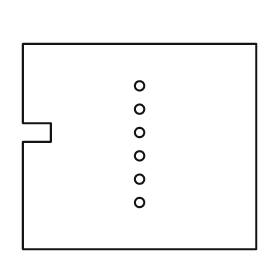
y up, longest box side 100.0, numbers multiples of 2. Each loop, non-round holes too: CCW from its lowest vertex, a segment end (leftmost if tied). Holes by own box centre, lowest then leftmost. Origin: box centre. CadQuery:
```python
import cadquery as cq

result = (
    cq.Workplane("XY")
    .moveTo(-50.0, -44.0)
    .lineTo(50.0, -44.0)
    .lineTo(50.0, 44.0)
    .lineTo(-50.0, 44.0)
    .lineTo(-50.0, 10.0)
    .lineTo(-38.0, 10.0)
    .lineTo(-38.0, 2.0)
    .lineTo(-50.0, 2.0)
    .close()
    .moveTo(0.0, -24.0)
    .circle(2.0)
    .moveTo(0.0, -14.0)
    .circle(2.0)
    .moveTo(0.0, -4.0)
    .circle(2.0)
    .moveTo(0.0, 6.0)
    .circle(2.0)
    .moveTo(0.0, 16.0)
    .circle(2.0)
    .moveTo(0.0, 26.0)
    .circle(2.0)
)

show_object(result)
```